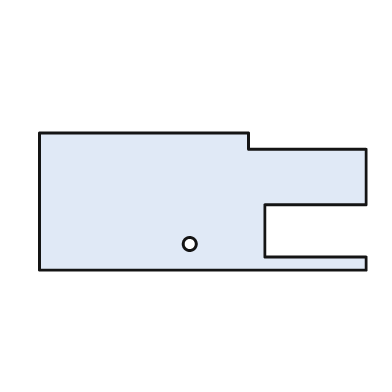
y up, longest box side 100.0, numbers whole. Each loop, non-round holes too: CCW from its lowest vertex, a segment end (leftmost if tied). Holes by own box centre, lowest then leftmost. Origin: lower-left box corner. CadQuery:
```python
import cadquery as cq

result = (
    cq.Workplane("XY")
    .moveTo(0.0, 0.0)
    .lineTo(100.0, 0.0)
    .lineTo(100.0, 4.0)
    .lineTo(69.0, 4.0)
    .lineTo(69.0, 20.0)
    .lineTo(100.0, 20.0)
    .lineTo(100.0, 37.0)
    .lineTo(64.0, 37.0)
    .lineTo(64.0, 42.0)
    .lineTo(0.0, 42.0)
    .close()
    .moveTo(46.0, 8.0)
    .circle(2.0)
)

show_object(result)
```